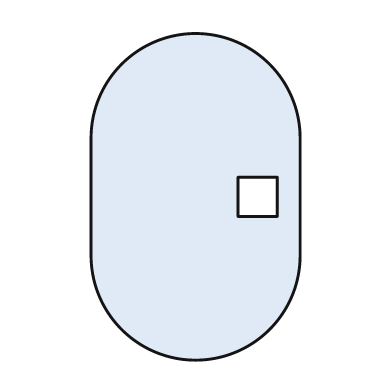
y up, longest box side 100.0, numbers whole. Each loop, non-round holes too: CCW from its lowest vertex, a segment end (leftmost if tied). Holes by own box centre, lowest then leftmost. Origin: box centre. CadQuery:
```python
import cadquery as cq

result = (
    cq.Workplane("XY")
    .moveTo(-32.0, -18.0)
    .threePointArc((0.0, -50.0), (32.0, -18.0))
    .lineTo(32.0, 18.0)
    .threePointArc((0.0, 50.0), (-32.0, 18.0))
    .close()
    .moveTo(13.0, -6.0)
    .lineTo(25.0, -6.0)
    .lineTo(25.0, 6.0)
    .lineTo(13.0, 6.0)
    .close()
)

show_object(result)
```